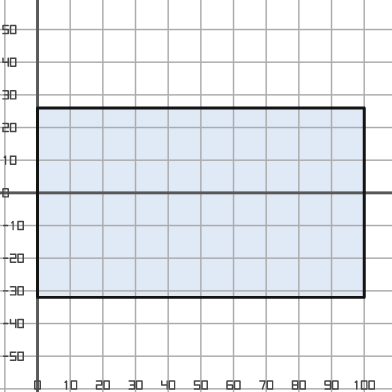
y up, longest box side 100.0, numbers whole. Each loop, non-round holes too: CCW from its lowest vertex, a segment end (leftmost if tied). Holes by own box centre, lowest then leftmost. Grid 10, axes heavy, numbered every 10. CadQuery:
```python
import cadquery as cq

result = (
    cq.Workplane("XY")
    .moveTo(0.0, -32.0)
    .lineTo(100.0, -32.0)
    .lineTo(100.0, 26.0)
    .lineTo(0.0, 26.0)
    .close()
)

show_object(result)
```